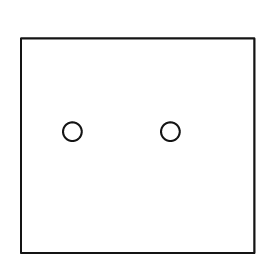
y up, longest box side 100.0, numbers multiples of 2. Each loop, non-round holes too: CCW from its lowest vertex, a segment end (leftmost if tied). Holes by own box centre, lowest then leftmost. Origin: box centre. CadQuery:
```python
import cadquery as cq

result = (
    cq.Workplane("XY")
    .moveTo(-50.0, -46.0)
    .lineTo(50.0, -46.0)
    .lineTo(50.0, 46.0)
    .lineTo(-50.0, 46.0)
    .close()
    .moveTo(-28.0, 6.0)
    .circle(4.0)
    .moveTo(14.0, 6.0)
    .circle(4.0)
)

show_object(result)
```